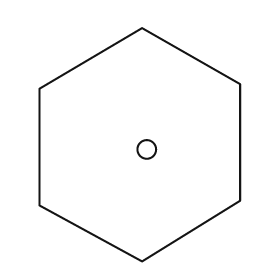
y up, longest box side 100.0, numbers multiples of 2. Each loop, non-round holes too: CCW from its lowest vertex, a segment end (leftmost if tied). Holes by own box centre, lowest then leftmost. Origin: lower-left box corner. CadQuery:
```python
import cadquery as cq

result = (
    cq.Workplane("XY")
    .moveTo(44.0, 0.0)
    .lineTo(86.0, 26.0)
    .lineTo(86.0, 76.0)
    .lineTo(44.0, 100.0)
    .lineTo(0.0, 74.0)
    .lineTo(0.0, 24.0)
    .close()
    .moveTo(46.0, 48.0)
    .circle(4.0)
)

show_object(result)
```